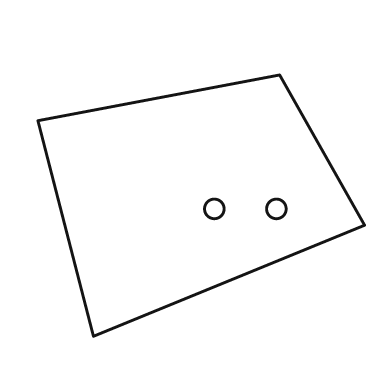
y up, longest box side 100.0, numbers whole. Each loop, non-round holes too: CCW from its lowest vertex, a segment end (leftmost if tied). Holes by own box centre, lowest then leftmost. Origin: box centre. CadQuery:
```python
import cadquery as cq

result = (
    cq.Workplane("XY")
    .moveTo(-33.0, -40.0)
    .lineTo(50.0, -6.0)
    .lineTo(24.0, 40.0)
    .lineTo(-50.0, 26.0)
    .close()
    .moveTo(4.0, -1.0)
    .circle(3.0)
    .moveTo(23.0, -1.0)
    .circle(3.0)
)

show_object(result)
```